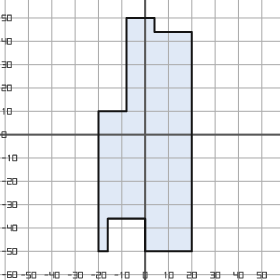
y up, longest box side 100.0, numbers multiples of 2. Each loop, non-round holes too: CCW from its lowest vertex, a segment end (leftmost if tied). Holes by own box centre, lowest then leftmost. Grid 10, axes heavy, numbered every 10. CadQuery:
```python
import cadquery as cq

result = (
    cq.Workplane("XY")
    .moveTo(-20.0, -50.0)
    .lineTo(-16.0, -50.0)
    .lineTo(-16.0, -36.0)
    .lineTo(0.0, -36.0)
    .lineTo(0.0, -50.0)
    .lineTo(20.0, -50.0)
    .lineTo(20.0, 44.0)
    .lineTo(4.0, 44.0)
    .lineTo(4.0, 50.0)
    .lineTo(-8.0, 50.0)
    .lineTo(-8.0, 10.0)
    .lineTo(-20.0, 10.0)
    .close()
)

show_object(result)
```